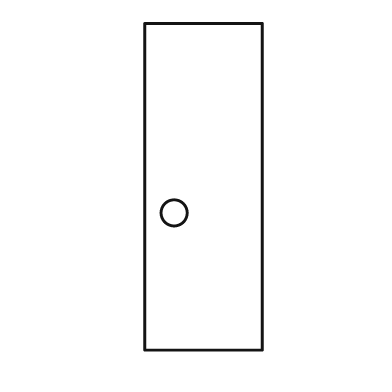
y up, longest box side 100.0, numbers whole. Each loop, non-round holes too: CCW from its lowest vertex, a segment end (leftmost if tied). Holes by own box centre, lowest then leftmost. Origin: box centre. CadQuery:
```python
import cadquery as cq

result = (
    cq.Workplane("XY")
    .moveTo(-18.0, -50.0)
    .lineTo(18.0, -50.0)
    .lineTo(18.0, 50.0)
    .lineTo(-18.0, 50.0)
    .close()
    .moveTo(-9.0, -8.0)
    .circle(4.0)
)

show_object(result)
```